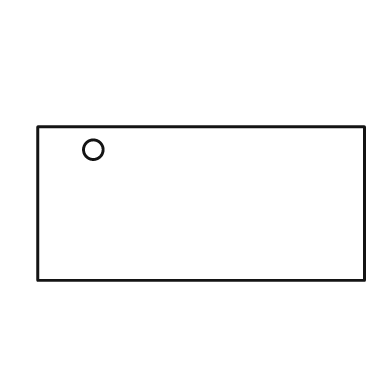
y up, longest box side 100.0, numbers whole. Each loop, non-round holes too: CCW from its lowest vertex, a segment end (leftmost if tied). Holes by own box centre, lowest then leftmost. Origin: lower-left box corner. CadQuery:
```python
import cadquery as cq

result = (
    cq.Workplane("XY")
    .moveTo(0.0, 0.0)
    .lineTo(100.0, 0.0)
    .lineTo(100.0, 47.0)
    .lineTo(0.0, 47.0)
    .close()
    .moveTo(17.0, 40.0)
    .circle(3.0)
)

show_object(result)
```